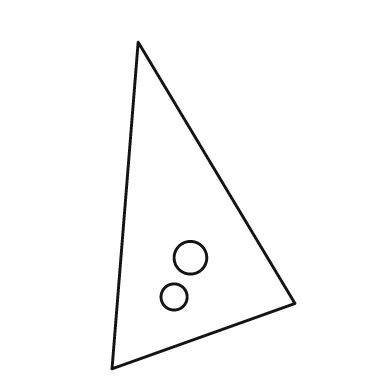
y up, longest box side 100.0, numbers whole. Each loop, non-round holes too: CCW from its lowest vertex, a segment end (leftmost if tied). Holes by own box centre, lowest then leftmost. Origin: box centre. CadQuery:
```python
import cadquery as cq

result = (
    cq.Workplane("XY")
    .moveTo(-28.0, -50.0)
    .lineTo(28.0, -30.0)
    .lineTo(-20.0, 50.0)
    .close()
    .moveTo(-9.0, -28.0)
    .circle(4.0)
    .moveTo(-4.0, -16.0)
    .circle(5.0)
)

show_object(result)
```